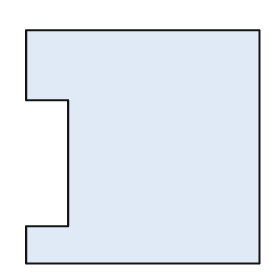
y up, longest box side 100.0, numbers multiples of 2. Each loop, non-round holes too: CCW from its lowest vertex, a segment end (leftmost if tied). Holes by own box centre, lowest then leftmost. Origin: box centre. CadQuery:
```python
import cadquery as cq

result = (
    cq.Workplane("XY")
    .moveTo(-50.0, -50.0)
    .lineTo(50.0, -50.0)
    .lineTo(50.0, 50.0)
    .lineTo(-50.0, 50.0)
    .lineTo(-50.0, 20.0)
    .lineTo(-32.0, 20.0)
    .lineTo(-32.0, -34.0)
    .lineTo(-50.0, -34.0)
    .close()
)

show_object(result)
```